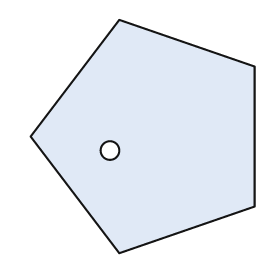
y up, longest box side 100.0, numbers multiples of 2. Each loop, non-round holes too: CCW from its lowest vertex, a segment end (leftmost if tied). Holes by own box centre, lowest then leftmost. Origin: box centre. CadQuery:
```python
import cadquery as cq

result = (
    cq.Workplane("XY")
    .moveTo(-10.0, -50.0)
    .lineTo(48.0, -30.0)
    .lineTo(48.0, 30.0)
    .lineTo(-10.0, 50.0)
    .lineTo(-48.0, 0.0)
    .close()
    .moveTo(-14.0, -6.0)
    .circle(4.0)
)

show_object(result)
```